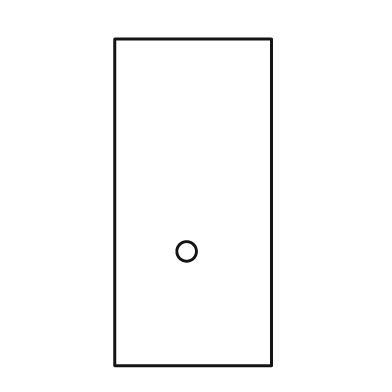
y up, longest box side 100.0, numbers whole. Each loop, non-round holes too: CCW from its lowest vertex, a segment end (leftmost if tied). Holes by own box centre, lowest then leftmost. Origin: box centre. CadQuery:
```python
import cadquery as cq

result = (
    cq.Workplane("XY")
    .moveTo(-24.0, -50.0)
    .lineTo(24.0, -50.0)
    .lineTo(24.0, 50.0)
    .lineTo(-24.0, 50.0)
    .close()
    .moveTo(-2.0, -15.0)
    .circle(3.0)
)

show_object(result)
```